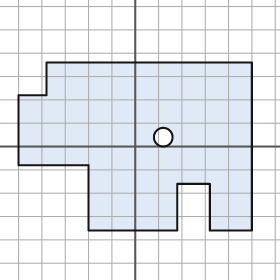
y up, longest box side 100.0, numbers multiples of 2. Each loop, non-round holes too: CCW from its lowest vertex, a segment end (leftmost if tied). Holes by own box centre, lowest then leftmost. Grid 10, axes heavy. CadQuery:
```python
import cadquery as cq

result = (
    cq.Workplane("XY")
    .moveTo(-20.0, -36.0)
    .lineTo(18.0, -36.0)
    .lineTo(18.0, -16.0)
    .lineTo(32.0, -16.0)
    .lineTo(32.0, -36.0)
    .lineTo(50.0, -36.0)
    .lineTo(50.0, 36.0)
    .lineTo(-38.0, 36.0)
    .lineTo(-38.0, 22.0)
    .lineTo(-50.0, 22.0)
    .lineTo(-50.0, -8.0)
    .lineTo(-20.0, -8.0)
    .close()
    .moveTo(12.0, 4.0)
    .circle(4.0)
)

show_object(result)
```